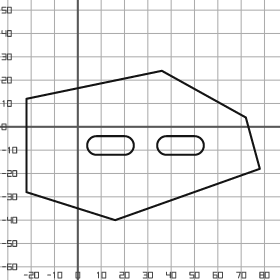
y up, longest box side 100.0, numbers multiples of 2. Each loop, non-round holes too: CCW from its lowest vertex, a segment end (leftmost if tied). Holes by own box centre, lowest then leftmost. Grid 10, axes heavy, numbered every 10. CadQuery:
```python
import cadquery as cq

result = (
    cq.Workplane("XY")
    .moveTo(16.0, -40.0)
    .lineTo(78.0, -18.0)
    .lineTo(72.0, 4.0)
    .lineTo(36.0, 24.0)
    .lineTo(-22.0, 12.0)
    .lineTo(-22.0, -28.0)
    .close()
    .moveTo(8.0, -12.0)
    .lineTo(20.0, -12.0)
    .threePointArc((24.0, -8.0), (20.0, -4.0))
    .lineTo(8.0, -4.0)
    .threePointArc((4.0, -8.0), (8.0, -12.0))
    .close()
    .moveTo(38.0, -12.0)
    .lineTo(50.0, -12.0)
    .threePointArc((54.0, -8.0), (50.0, -4.0))
    .lineTo(38.0, -4.0)
    .threePointArc((34.0, -8.0), (38.0, -12.0))
    .close()
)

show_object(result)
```